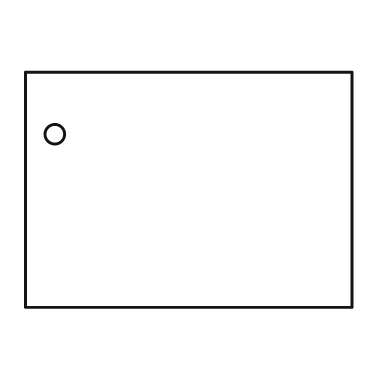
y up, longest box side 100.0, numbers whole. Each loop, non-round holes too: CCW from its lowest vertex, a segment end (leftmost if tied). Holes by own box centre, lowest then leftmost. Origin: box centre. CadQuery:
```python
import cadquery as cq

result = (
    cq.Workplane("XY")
    .moveTo(-50.0, -36.0)
    .lineTo(50.0, -36.0)
    .lineTo(50.0, 36.0)
    .lineTo(-50.0, 36.0)
    .close()
    .moveTo(-41.0, 17.0)
    .circle(3.0)
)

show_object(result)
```